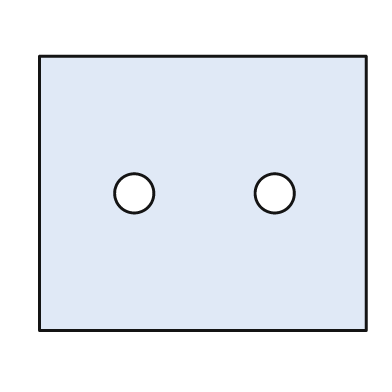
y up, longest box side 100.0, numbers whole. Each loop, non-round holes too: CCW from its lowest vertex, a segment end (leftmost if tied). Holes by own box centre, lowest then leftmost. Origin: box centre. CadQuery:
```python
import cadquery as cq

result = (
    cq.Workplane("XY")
    .moveTo(-50.0, -42.0)
    .lineTo(50.0, -42.0)
    .lineTo(50.0, 42.0)
    .lineTo(-50.0, 42.0)
    .close()
    .moveTo(-21.0, 0.0)
    .circle(6.0)
    .moveTo(22.0, 0.0)
    .circle(6.0)
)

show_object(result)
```